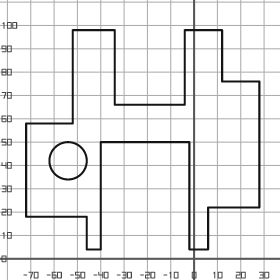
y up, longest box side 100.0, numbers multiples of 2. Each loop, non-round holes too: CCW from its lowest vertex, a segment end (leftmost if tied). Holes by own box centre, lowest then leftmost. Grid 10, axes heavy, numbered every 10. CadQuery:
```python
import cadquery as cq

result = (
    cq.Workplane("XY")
    .moveTo(-46.0, 4.0)
    .lineTo(-40.0, 4.0)
    .lineTo(-40.0, 50.0)
    .lineTo(-2.0, 50.0)
    .lineTo(-2.0, 4.0)
    .lineTo(6.0, 4.0)
    .lineTo(6.0, 22.0)
    .lineTo(28.0, 22.0)
    .lineTo(28.0, 76.0)
    .lineTo(12.0, 76.0)
    .lineTo(12.0, 98.0)
    .lineTo(-4.0, 98.0)
    .lineTo(-4.0, 66.0)
    .lineTo(-34.0, 66.0)
    .lineTo(-34.0, 98.0)
    .lineTo(-52.0, 98.0)
    .lineTo(-52.0, 58.0)
    .lineTo(-72.0, 58.0)
    .lineTo(-72.0, 18.0)
    .lineTo(-46.0, 18.0)
    .close()
    .moveTo(-54.0, 42.0)
    .circle(8.0)
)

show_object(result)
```